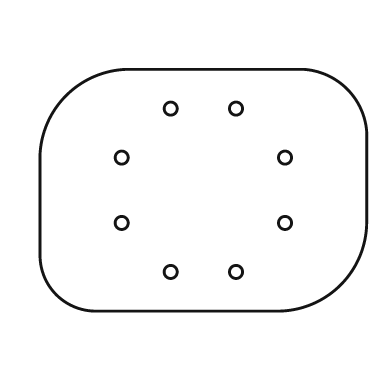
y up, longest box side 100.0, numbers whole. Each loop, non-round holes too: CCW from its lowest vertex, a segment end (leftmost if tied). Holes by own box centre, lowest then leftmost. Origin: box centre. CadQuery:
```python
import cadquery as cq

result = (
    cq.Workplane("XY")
    .moveTo(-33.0, -37.0)
    .lineTo(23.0, -37.0)
    .threePointArc((42.0, -29.0), (50.0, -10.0))
    .lineTo(50.0, 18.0)
    .threePointArc((44.0, 31.0), (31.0, 37.0))
    .lineTo(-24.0, 37.0)
    .threePointArc((-42.0, 29.0), (-50.0, 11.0))
    .lineTo(-50.0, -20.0)
    .threePointArc((-45.0, -32.0), (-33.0, -37.0))
    .close()
    .moveTo(-10.0, -25.0)
    .circle(2.0)
    .moveTo(10.0, -25.0)
    .circle(2.0)
    .moveTo(-25.0, -10.0)
    .circle(2.0)
    .moveTo(25.0, -10.0)
    .circle(2.0)
    .moveTo(-25.0, 10.0)
    .circle(2.0)
    .moveTo(25.0, 10.0)
    .circle(2.0)
    .moveTo(-10.0, 25.0)
    .circle(2.0)
    .moveTo(10.0, 25.0)
    .circle(2.0)
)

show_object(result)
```